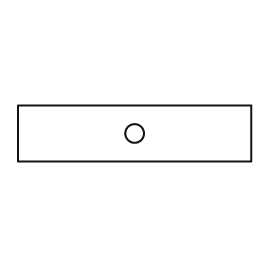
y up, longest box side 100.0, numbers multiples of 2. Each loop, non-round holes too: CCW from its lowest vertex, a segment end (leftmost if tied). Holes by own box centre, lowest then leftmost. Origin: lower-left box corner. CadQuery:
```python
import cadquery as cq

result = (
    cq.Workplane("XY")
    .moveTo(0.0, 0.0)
    .lineTo(100.0, 0.0)
    .lineTo(100.0, 24.0)
    .lineTo(0.0, 24.0)
    .close()
    .moveTo(50.0, 12.0)
    .circle(4.0)
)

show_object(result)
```